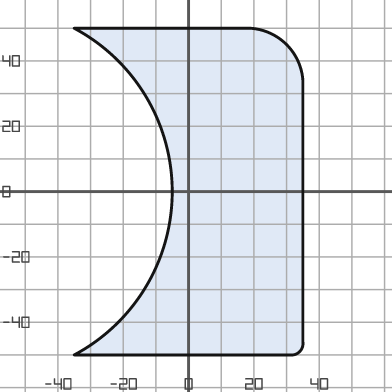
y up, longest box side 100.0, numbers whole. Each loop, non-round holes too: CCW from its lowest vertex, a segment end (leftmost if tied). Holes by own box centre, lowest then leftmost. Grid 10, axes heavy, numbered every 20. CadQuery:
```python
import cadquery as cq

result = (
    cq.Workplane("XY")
    .moveTo(-35.0, -50.0)
    .lineTo(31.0, -50.0)
    .threePointArc((34.0, -49.0), (35.0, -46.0))
    .lineTo(35.0, 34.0)
    .threePointArc((30.0, 45.0), (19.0, 50.0))
    .lineTo(-35.0, 50.0)
    .threePointArc((-5.0, 0.0), (-35.0, -50.0))
    .close()
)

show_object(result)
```